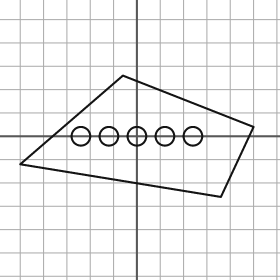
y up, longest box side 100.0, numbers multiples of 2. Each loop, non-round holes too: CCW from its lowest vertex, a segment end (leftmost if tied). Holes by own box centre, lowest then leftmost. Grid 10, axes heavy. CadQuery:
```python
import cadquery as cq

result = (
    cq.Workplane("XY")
    .moveTo(36.0, -26.0)
    .lineTo(50.0, 4.0)
    .lineTo(-6.0, 26.0)
    .lineTo(-50.0, -12.0)
    .close()
    .moveTo(-24.0, 0.0)
    .circle(4.0)
    .moveTo(-12.0, 0.0)
    .circle(4.0)
    .moveTo(0.0, 0.0)
    .circle(4.0)
    .moveTo(12.0, 0.0)
    .circle(4.0)
    .moveTo(24.0, 0.0)
    .circle(4.0)
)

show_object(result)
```